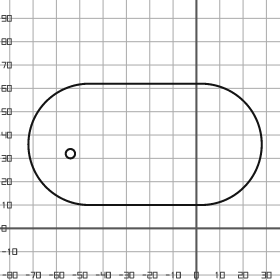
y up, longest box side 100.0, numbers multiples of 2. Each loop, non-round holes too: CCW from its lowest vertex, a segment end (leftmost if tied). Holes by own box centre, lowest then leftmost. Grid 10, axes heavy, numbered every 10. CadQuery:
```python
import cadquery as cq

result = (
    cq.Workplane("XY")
    .moveTo(-46.0, 10.0)
    .lineTo(2.0, 10.0)
    .threePointArc((28.0, 36.0), (2.0, 62.0))
    .lineTo(-46.0, 62.0)
    .threePointArc((-72.0, 36.0), (-46.0, 10.0))
    .close()
    .moveTo(-54.0, 32.0)
    .circle(2.0)
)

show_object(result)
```